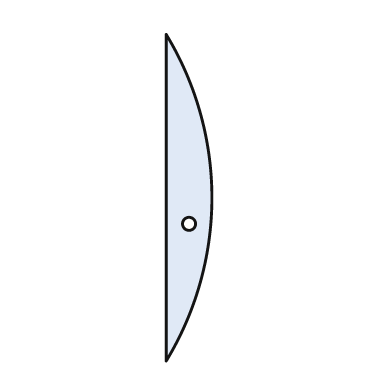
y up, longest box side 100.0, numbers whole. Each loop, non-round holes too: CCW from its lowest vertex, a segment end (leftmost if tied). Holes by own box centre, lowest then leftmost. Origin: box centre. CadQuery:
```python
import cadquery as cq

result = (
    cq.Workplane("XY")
    .moveTo(-7.0, -50.0)
    .threePointArc((7.0, 0.0), (-7.0, 50.0))
    .close()
    .moveTo(0.0, -8.0)
    .circle(2.0)
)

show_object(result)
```